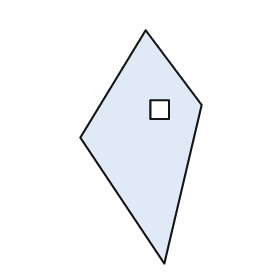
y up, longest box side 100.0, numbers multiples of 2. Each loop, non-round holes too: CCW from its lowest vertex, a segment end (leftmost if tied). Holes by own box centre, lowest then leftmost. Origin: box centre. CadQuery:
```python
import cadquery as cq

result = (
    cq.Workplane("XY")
    .moveTo(10.0, -50.0)
    .lineTo(26.0, 18.0)
    .lineTo(2.0, 50.0)
    .lineTo(-26.0, 4.0)
    .close()
    .moveTo(4.0, 12.0)
    .lineTo(12.0, 12.0)
    .lineTo(12.0, 20.0)
    .lineTo(4.0, 20.0)
    .close()
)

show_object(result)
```